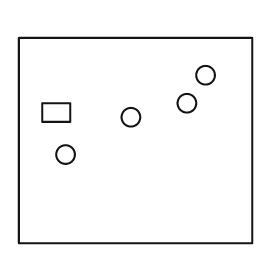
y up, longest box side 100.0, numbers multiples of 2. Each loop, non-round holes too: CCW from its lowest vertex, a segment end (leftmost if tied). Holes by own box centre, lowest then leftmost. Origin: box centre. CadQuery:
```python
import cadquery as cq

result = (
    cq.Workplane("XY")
    .moveTo(-50.0, -44.0)
    .lineTo(50.0, -44.0)
    .lineTo(50.0, 44.0)
    .lineTo(-50.0, 44.0)
    .close()
    .moveTo(-30.0, -6.0)
    .circle(4.0)
    .moveTo(-2.0, 10.0)
    .circle(4.0)
    .moveTo(-40.0, 8.0)
    .lineTo(-28.0, 8.0)
    .lineTo(-28.0, 16.0)
    .lineTo(-40.0, 16.0)
    .close()
    .moveTo(22.0, 16.0)
    .circle(4.0)
    .moveTo(30.0, 28.0)
    .circle(4.0)
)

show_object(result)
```